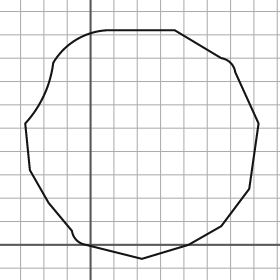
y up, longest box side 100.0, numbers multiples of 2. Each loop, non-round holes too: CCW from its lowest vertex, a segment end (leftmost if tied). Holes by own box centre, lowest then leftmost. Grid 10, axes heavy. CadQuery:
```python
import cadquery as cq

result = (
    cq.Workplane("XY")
    .moveTo(22.0, -6.0)
    .lineTo(42.0, 0.0)
    .lineTo(56.0, 8.0)
    .lineTo(68.0, 24.0)
    .lineTo(72.0, 52.0)
    .lineTo(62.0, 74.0)
    .threePointArc((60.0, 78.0), (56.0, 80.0))
    .lineTo(36.0, 92.0)
    .lineTo(8.0, 92.0)
    .threePointArc((-6.0, 88.0), (-16.0, 78.0))
    .threePointArc((-20.0, 64.0), (-28.0, 52.0))
    .lineTo(-26.0, 32.0)
    .lineTo(-18.0, 18.0)
    .lineTo(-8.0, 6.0)
    .threePointArc((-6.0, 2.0), (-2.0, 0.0))
    .close()
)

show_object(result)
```